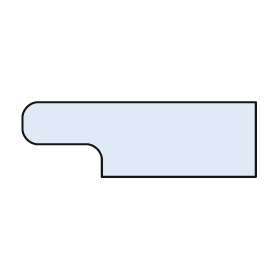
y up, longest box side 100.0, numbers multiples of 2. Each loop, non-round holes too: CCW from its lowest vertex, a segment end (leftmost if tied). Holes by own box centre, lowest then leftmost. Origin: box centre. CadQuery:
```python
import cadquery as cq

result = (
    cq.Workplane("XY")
    .moveTo(-16.0, -16.0)
    .lineTo(50.0, -16.0)
    .lineTo(50.0, 16.0)
    .lineTo(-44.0, 16.0)
    .threePointArc((-48.0, 14.0), (-50.0, 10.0))
    .lineTo(-50.0, 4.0)
    .threePointArc((-48.0, 0.0), (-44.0, -2.0))
    .lineTo(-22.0, -2.0)
    .threePointArc((-18.0, -4.0), (-16.0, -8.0))
    .close()
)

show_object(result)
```